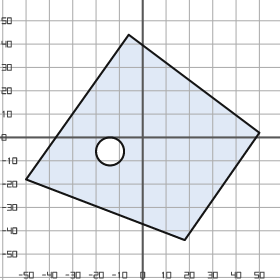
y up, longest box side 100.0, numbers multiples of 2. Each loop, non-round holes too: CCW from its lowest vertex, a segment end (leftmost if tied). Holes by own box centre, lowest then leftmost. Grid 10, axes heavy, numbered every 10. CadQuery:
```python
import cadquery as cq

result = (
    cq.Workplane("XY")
    .moveTo(18.0, -44.0)
    .lineTo(50.0, 2.0)
    .lineTo(-6.0, 44.0)
    .lineTo(-50.0, -18.0)
    .close()
    .moveTo(-14.0, -6.0)
    .circle(6.0)
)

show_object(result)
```